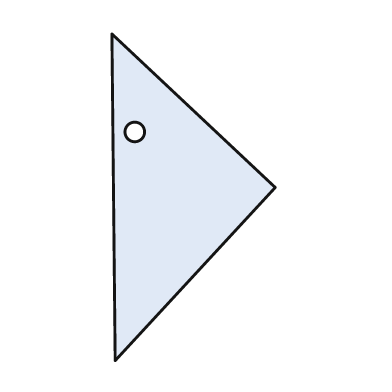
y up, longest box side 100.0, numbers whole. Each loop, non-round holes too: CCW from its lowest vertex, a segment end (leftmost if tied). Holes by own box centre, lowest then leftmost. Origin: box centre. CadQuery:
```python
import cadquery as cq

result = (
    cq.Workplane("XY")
    .moveTo(-24.0, -50.0)
    .lineTo(25.0, 3.0)
    .lineTo(-25.0, 50.0)
    .close()
    .moveTo(-18.0, 20.0)
    .circle(3.0)
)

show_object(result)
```